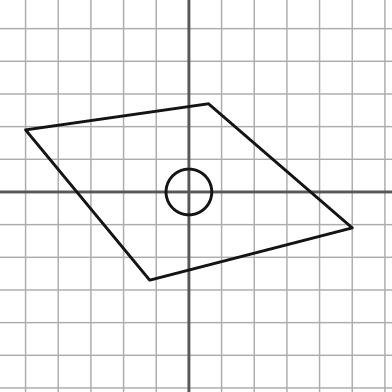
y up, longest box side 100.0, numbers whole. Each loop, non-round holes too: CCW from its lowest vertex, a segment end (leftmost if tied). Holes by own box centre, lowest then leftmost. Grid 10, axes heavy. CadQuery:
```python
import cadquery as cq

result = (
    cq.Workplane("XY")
    .moveTo(-12.0, -27.0)
    .lineTo(50.0, -11.0)
    .lineTo(6.0, 27.0)
    .lineTo(-50.0, 19.0)
    .close()
    .moveTo(0.0, 0.0)
    .circle(7.0)
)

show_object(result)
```